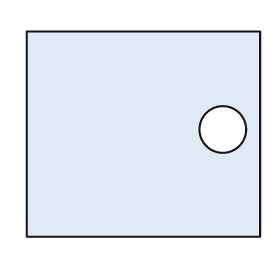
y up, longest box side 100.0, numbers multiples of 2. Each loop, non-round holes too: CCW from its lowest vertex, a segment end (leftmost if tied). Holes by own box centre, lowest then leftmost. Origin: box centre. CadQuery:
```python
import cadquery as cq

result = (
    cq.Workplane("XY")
    .moveTo(-50.0, -44.0)
    .lineTo(50.0, -44.0)
    .lineTo(50.0, 44.0)
    .lineTo(-50.0, 44.0)
    .close()
    .moveTo(34.0, 2.0)
    .circle(10.0)
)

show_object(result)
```